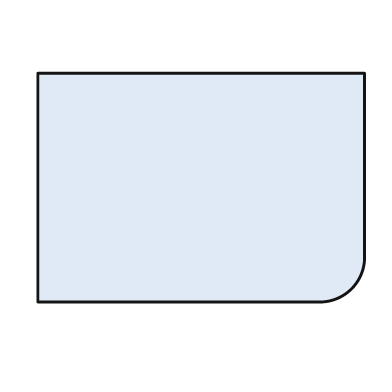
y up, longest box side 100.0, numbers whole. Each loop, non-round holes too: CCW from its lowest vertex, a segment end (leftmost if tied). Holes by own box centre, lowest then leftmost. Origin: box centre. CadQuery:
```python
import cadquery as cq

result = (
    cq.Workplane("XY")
    .moveTo(-50.0, -35.0)
    .lineTo(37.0, -35.0)
    .threePointArc((46.0, -31.0), (50.0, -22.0))
    .lineTo(50.0, 35.0)
    .lineTo(-50.0, 35.0)
    .close()
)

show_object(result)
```